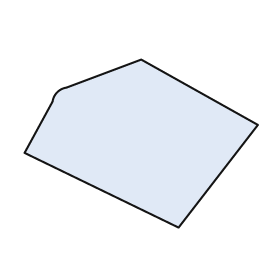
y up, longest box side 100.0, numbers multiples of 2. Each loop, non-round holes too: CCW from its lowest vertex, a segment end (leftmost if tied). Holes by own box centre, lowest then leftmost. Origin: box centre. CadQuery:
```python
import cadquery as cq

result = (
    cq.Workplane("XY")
    .moveTo(16.0, -36.0)
    .lineTo(50.0, 8.0)
    .lineTo(0.0, 36.0)
    .lineTo(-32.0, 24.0)
    .threePointArc((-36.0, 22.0), (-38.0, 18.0))
    .lineTo(-50.0, -4.0)
    .close()
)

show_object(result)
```